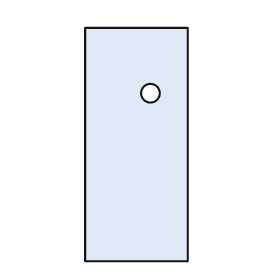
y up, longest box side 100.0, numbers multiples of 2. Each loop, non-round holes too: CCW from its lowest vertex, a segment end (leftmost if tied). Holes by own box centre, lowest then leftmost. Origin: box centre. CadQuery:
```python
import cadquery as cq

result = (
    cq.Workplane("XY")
    .moveTo(-22.0, -50.0)
    .lineTo(22.0, -50.0)
    .lineTo(22.0, 50.0)
    .lineTo(-22.0, 50.0)
    .close()
    .moveTo(6.0, 22.0)
    .circle(4.0)
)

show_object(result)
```